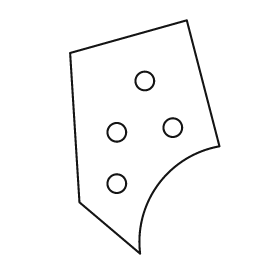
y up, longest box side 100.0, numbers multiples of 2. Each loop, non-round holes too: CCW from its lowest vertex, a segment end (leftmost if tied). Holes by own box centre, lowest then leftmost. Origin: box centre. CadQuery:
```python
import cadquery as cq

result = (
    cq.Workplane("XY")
    .moveTo(-2.0, -50.0)
    .threePointArc((6.0, -20.0), (32.0, -4.0))
    .lineTo(18.0, 50.0)
    .lineTo(-32.0, 36.0)
    .lineTo(-28.0, -28.0)
    .close()
    .moveTo(-12.0, -20.0)
    .circle(4.0)
    .moveTo(-12.0, 2.0)
    .circle(4.0)
    .moveTo(12.0, 4.0)
    .circle(4.0)
    .moveTo(0.0, 24.0)
    .circle(4.0)
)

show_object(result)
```